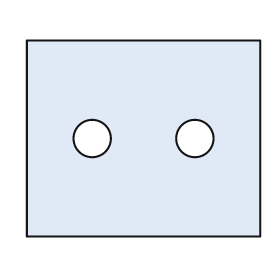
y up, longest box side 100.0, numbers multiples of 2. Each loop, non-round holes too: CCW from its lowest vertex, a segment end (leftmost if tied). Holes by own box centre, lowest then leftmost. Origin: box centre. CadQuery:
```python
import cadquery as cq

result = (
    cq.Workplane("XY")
    .moveTo(-50.0, -42.0)
    .lineTo(50.0, -42.0)
    .lineTo(50.0, 42.0)
    .lineTo(-50.0, 42.0)
    .close()
    .moveTo(-22.0, 0.0)
    .circle(8.0)
    .moveTo(22.0, 0.0)
    .circle(8.0)
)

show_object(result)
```